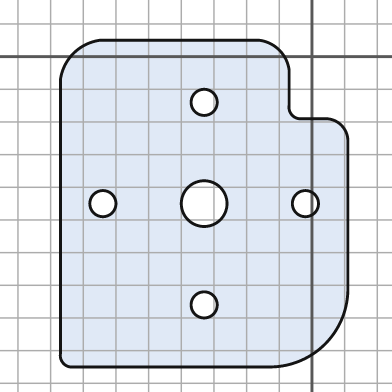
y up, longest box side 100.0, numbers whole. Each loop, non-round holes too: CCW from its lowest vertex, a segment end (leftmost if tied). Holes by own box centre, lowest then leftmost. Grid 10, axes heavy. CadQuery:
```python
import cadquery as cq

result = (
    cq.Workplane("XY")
    .moveTo(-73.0, -95.0)
    .lineTo(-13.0, -95.0)
    .threePointArc((4.0, -88.0), (11.0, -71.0))
    .lineTo(11.0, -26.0)
    .threePointArc((9.0, -21.0), (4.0, -19.0))
    .lineTo(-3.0, -19.0)
    .threePointArc((-6.0, -18.0), (-7.0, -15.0))
    .lineTo(-7.0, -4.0)
    .threePointArc((-10.0, 2.0), (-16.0, 5.0))
    .lineTo(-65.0, 5.0)
    .threePointArc((-73.0, 1.0), (-77.0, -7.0))
    .lineTo(-77.0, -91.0)
    .threePointArc((-76.0, -94.0), (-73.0, -95.0))
    .close()
    .moveTo(-33.0, -76.0)
    .circle(4.0)
    .moveTo(-64.0, -45.0)
    .circle(4.0)
    .moveTo(-33.0, -45.0)
    .circle(7.0)
    .moveTo(-2.0, -45.0)
    .circle(4.0)
    .moveTo(-33.0, -14.0)
    .circle(4.0)
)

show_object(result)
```